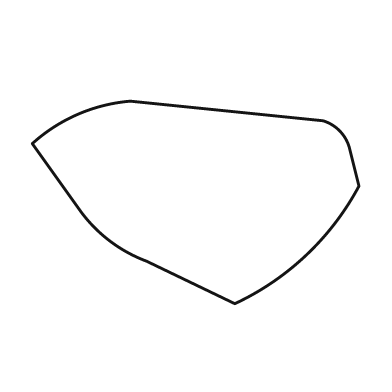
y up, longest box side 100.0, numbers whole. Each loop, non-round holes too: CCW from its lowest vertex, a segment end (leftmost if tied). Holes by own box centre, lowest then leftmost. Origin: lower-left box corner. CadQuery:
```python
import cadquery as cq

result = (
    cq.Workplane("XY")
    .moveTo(62.0, 0.0)
    .threePointArc((84.0, 15.0), (100.0, 36.0))
    .lineTo(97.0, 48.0)
    .threePointArc((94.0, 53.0), (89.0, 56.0))
    .lineTo(30.0, 62.0)
    .threePointArc((14.0, 58.0), (0.0, 49.0))
    .lineTo(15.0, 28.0)
    .threePointArc((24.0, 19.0), (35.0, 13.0))
    .close()
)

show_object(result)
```